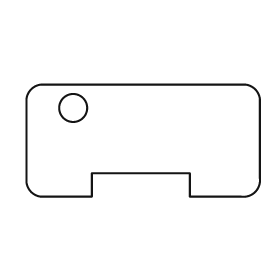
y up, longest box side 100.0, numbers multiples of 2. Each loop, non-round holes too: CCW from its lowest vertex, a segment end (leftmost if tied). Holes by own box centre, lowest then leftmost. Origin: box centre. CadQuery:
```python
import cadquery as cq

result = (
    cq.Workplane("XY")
    .moveTo(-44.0, -24.0)
    .lineTo(-22.0, -24.0)
    .lineTo(-22.0, -14.0)
    .lineTo(20.0, -14.0)
    .lineTo(20.0, -24.0)
    .lineTo(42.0, -24.0)
    .threePointArc((48.0, -22.0), (50.0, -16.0))
    .lineTo(50.0, 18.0)
    .threePointArc((48.0, 22.0), (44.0, 24.0))
    .lineTo(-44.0, 24.0)
    .threePointArc((-48.0, 22.0), (-50.0, 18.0))
    .lineTo(-50.0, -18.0)
    .threePointArc((-48.0, -22.0), (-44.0, -24.0))
    .close()
    .moveTo(-30.0, 14.0)
    .circle(6.0)
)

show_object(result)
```